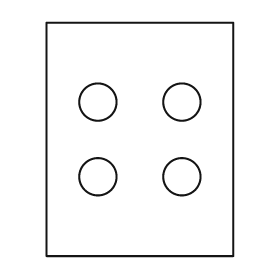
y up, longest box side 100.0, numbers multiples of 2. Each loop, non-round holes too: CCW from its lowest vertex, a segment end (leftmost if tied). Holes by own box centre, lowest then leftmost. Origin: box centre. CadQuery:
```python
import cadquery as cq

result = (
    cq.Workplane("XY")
    .moveTo(-40.0, -50.0)
    .lineTo(40.0, -50.0)
    .lineTo(40.0, 50.0)
    .lineTo(-40.0, 50.0)
    .close()
    .moveTo(-18.0, -16.0)
    .circle(8.0)
    .moveTo(18.0, -16.0)
    .circle(8.0)
    .moveTo(-18.0, 16.0)
    .circle(8.0)
    .moveTo(18.0, 16.0)
    .circle(8.0)
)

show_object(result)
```